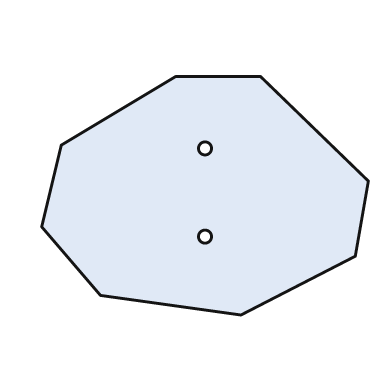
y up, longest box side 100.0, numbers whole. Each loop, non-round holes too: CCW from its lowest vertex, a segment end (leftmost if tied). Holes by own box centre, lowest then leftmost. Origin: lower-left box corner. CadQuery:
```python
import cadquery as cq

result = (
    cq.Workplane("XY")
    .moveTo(61.0, 0.0)
    .lineTo(96.0, 18.0)
    .lineTo(100.0, 41.0)
    .lineTo(67.0, 73.0)
    .lineTo(41.0, 73.0)
    .lineTo(6.0, 52.0)
    .lineTo(0.0, 27.0)
    .lineTo(18.0, 6.0)
    .close()
    .moveTo(50.0, 24.0)
    .circle(2.0)
    .moveTo(50.0, 51.0)
    .circle(2.0)
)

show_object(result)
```